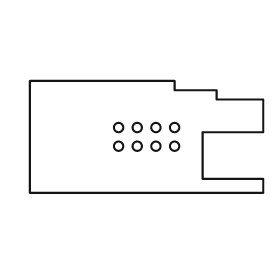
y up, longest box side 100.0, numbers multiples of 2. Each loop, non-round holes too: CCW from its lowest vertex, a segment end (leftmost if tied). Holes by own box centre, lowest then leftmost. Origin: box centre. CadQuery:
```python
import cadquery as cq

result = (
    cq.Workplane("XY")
    .moveTo(-50.0, -24.0)
    .lineTo(50.0, -24.0)
    .lineTo(50.0, -18.0)
    .lineTo(24.0, -18.0)
    .lineTo(24.0, 2.0)
    .lineTo(50.0, 2.0)
    .lineTo(50.0, 16.0)
    .lineTo(30.0, 16.0)
    .lineTo(30.0, 20.0)
    .lineTo(12.0, 20.0)
    .lineTo(12.0, 24.0)
    .lineTo(-50.0, 24.0)
    .close()
    .moveTo(-12.0, -4.0)
    .circle(2.0)
    .moveTo(-4.0, -4.0)
    .circle(2.0)
    .moveTo(4.0, -4.0)
    .circle(2.0)
    .moveTo(12.0, -4.0)
    .circle(2.0)
    .moveTo(-12.0, 4.0)
    .circle(2.0)
    .moveTo(-4.0, 4.0)
    .circle(2.0)
    .moveTo(4.0, 4.0)
    .circle(2.0)
    .moveTo(12.0, 4.0)
    .circle(2.0)
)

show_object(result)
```